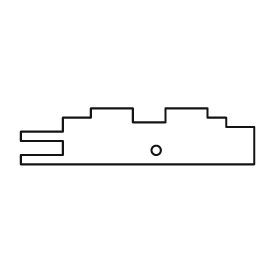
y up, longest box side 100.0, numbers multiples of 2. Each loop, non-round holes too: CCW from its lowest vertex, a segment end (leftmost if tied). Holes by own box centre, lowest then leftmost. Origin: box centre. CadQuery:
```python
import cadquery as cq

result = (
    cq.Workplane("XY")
    .moveTo(-50.0, -12.0)
    .lineTo(50.0, -12.0)
    .lineTo(50.0, 4.0)
    .lineTo(38.0, 4.0)
    .lineTo(38.0, 8.0)
    .lineTo(30.0, 8.0)
    .lineTo(30.0, 12.0)
    .lineTo(12.0, 12.0)
    .lineTo(12.0, 6.0)
    .lineTo(-2.0, 6.0)
    .lineTo(-2.0, 12.0)
    .lineTo(-20.0, 12.0)
    .lineTo(-20.0, 8.0)
    .lineTo(-32.0, 8.0)
    .lineTo(-32.0, 2.0)
    .lineTo(-50.0, 2.0)
    .lineTo(-50.0, -2.0)
    .lineTo(-32.0, -2.0)
    .lineTo(-32.0, -8.0)
    .lineTo(-50.0, -8.0)
    .close()
    .moveTo(8.0, -6.0)
    .circle(2.0)
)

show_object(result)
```